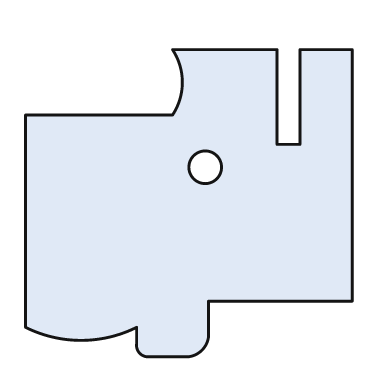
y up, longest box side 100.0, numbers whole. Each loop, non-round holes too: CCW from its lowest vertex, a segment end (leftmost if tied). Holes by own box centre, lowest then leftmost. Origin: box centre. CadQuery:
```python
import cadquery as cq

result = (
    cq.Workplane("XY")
    .moveTo(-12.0, -47.0)
    .lineTo(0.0, -47.0)
    .threePointArc((4.0, -45.0), (6.0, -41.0))
    .lineTo(6.0, -30.0)
    .lineTo(50.0, -30.0)
    .lineTo(50.0, 47.0)
    .lineTo(34.0, 47.0)
    .lineTo(34.0, 18.0)
    .lineTo(27.0, 18.0)
    .lineTo(27.0, 47.0)
    .lineTo(-5.0, 47.0)
    .threePointArc((-2.0, 37.0), (-5.0, 27.0))
    .lineTo(-50.0, 27.0)
    .lineTo(-50.0, -38.0)
    .threePointArc((-33.0, -42.0), (-16.0, -38.0))
    .lineTo(-16.0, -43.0)
    .threePointArc((-15.0, -46.0), (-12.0, -47.0))
    .close()
    .moveTo(5.0, 11.0)
    .circle(5.0)
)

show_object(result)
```